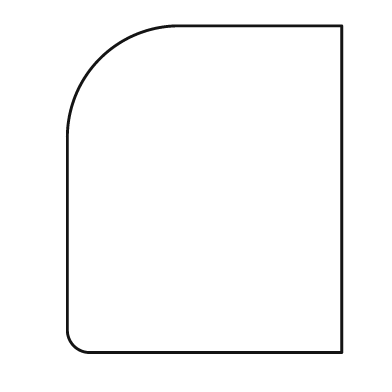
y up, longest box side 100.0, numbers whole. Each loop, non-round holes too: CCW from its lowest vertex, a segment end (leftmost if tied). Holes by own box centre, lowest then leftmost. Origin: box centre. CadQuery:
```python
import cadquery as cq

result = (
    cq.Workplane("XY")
    .moveTo(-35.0, -50.0)
    .lineTo(42.0, -50.0)
    .lineTo(42.0, 50.0)
    .lineTo(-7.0, 50.0)
    .threePointArc((-32.0, 40.0), (-42.0, 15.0))
    .lineTo(-42.0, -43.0)
    .threePointArc((-40.0, -48.0), (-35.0, -50.0))
    .close()
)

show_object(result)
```